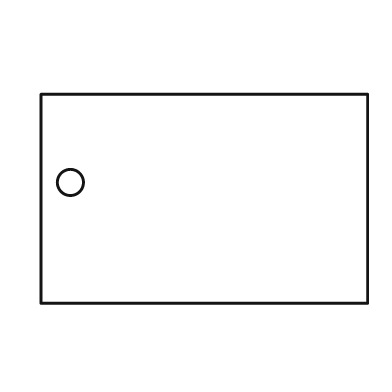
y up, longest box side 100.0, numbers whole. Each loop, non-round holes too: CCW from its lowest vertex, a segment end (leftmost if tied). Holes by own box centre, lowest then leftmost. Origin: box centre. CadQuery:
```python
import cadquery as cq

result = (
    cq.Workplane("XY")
    .moveTo(-50.0, -32.0)
    .lineTo(50.0, -32.0)
    .lineTo(50.0, 32.0)
    .lineTo(-50.0, 32.0)
    .close()
    .moveTo(-41.0, 5.0)
    .circle(4.0)
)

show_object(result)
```